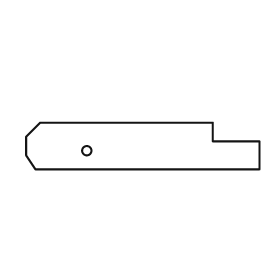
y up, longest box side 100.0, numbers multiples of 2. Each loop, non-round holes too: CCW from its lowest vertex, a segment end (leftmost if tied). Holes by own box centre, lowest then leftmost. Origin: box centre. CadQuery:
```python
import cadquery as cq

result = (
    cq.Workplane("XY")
    .moveTo(-46.0, -10.0)
    .lineTo(50.0, -10.0)
    .lineTo(50.0, 2.0)
    .lineTo(30.0, 2.0)
    .lineTo(30.0, 10.0)
    .lineTo(-44.0, 10.0)
    .lineTo(-50.0, 4.0)
    .lineTo(-50.0, -4.0)
    .close()
    .moveTo(-24.0, -2.0)
    .circle(2.0)
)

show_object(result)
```